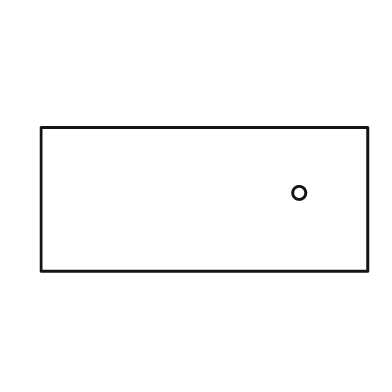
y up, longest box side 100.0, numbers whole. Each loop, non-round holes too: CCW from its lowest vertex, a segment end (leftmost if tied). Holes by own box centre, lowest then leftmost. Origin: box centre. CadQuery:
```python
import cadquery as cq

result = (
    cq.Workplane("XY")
    .moveTo(-50.0, -22.0)
    .lineTo(50.0, -22.0)
    .lineTo(50.0, 22.0)
    .lineTo(-50.0, 22.0)
    .close()
    .moveTo(29.0, 2.0)
    .circle(2.0)
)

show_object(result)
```